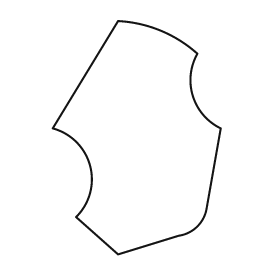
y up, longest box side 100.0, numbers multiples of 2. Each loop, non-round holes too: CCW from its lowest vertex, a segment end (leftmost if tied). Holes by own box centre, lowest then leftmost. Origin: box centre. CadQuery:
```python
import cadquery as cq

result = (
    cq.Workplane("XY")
    .moveTo(-8.0, -50.0)
    .lineTo(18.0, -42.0)
    .threePointArc((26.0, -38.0), (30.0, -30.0))
    .lineTo(36.0, 4.0)
    .threePointArc((24.0, 18.0), (26.0, 36.0))
    .threePointArc((10.0, 46.0), (-8.0, 50.0))
    .lineTo(-36.0, 4.0)
    .threePointArc((-20.0, -12.0), (-26.0, -34.0))
    .close()
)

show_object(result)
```